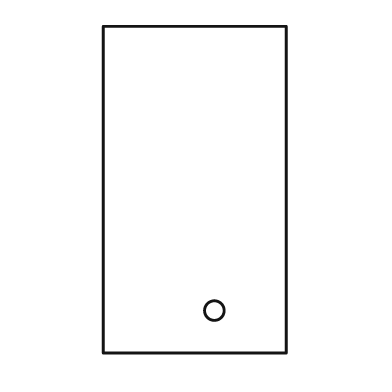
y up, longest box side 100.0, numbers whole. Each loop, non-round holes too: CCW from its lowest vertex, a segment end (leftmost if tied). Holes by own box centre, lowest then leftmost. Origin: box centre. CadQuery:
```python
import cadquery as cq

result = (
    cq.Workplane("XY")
    .moveTo(-28.0, -50.0)
    .lineTo(28.0, -50.0)
    .lineTo(28.0, 50.0)
    .lineTo(-28.0, 50.0)
    .close()
    .moveTo(6.0, -37.0)
    .circle(3.0)
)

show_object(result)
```